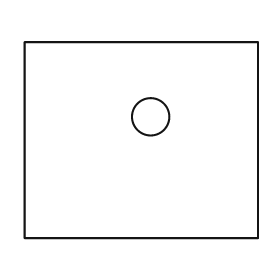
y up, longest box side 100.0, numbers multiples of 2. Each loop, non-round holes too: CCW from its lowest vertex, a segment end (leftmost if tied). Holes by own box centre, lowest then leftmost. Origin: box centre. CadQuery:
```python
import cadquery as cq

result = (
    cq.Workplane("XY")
    .moveTo(-50.0, -42.0)
    .lineTo(50.0, -42.0)
    .lineTo(50.0, 42.0)
    .lineTo(-50.0, 42.0)
    .close()
    .moveTo(4.0, 10.0)
    .circle(8.0)
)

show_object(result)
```